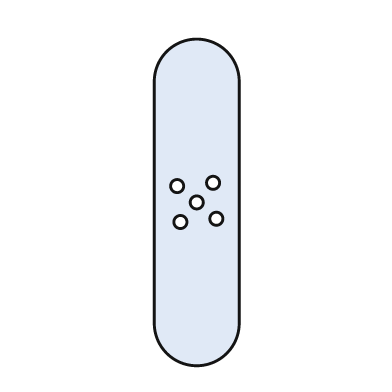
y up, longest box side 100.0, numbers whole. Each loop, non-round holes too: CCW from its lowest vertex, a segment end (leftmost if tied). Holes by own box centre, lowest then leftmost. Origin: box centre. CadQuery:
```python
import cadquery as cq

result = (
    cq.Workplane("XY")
    .moveTo(-13.0, -37.0)
    .threePointArc((0.0, -50.0), (13.0, -37.0))
    .lineTo(13.0, 37.0)
    .threePointArc((0.0, 50.0), (-13.0, 37.0))
    .close()
    .moveTo(-5.0, -6.0)
    .circle(2.0)
    .moveTo(6.0, -5.0)
    .circle(2.0)
    .moveTo(0.0, 0.0)
    .circle(2.0)
    .moveTo(-6.0, 5.0)
    .circle(2.0)
    .moveTo(5.0, 6.0)
    .circle(2.0)
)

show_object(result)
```